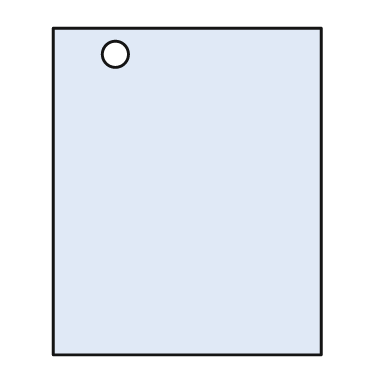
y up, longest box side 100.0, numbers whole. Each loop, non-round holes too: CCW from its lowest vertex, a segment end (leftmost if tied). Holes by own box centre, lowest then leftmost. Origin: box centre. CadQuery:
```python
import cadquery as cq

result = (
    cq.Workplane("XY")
    .moveTo(-41.0, -50.0)
    .lineTo(41.0, -50.0)
    .lineTo(41.0, 50.0)
    .lineTo(-41.0, 50.0)
    .close()
    .moveTo(-22.0, 42.0)
    .circle(4.0)
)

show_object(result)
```